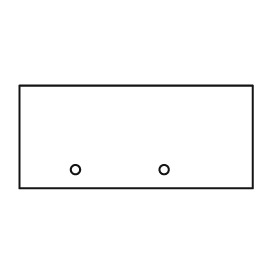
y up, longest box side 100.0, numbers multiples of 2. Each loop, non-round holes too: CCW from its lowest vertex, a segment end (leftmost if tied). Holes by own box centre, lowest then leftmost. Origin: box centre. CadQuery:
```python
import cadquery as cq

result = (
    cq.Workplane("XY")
    .moveTo(-50.0, -22.0)
    .lineTo(50.0, -22.0)
    .lineTo(50.0, 22.0)
    .lineTo(-50.0, 22.0)
    .close()
    .moveTo(-26.0, -14.0)
    .circle(2.0)
    .moveTo(12.0, -14.0)
    .circle(2.0)
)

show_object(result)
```